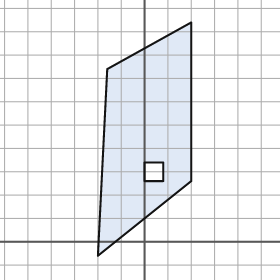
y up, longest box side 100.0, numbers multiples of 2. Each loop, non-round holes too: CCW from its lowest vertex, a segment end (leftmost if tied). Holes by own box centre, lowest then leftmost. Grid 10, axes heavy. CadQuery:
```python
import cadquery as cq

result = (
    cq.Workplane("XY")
    .moveTo(-20.0, -6.0)
    .lineTo(20.0, 26.0)
    .lineTo(20.0, 94.0)
    .lineTo(-16.0, 74.0)
    .close()
    .moveTo(0.0, 26.0)
    .lineTo(8.0, 26.0)
    .lineTo(8.0, 34.0)
    .lineTo(0.0, 34.0)
    .close()
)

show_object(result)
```